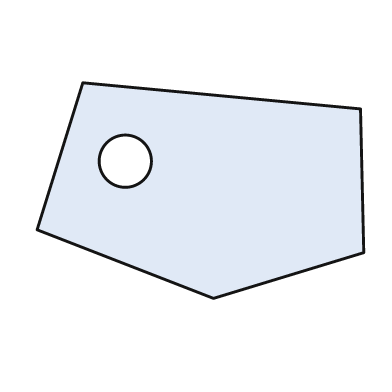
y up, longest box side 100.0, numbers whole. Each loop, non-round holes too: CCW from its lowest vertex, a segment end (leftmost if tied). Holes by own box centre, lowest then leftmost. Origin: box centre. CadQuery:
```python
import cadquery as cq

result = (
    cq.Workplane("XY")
    .moveTo(4.0, -33.0)
    .lineTo(50.0, -19.0)
    .lineTo(49.0, 25.0)
    .lineTo(-36.0, 33.0)
    .lineTo(-50.0, -12.0)
    .close()
    .moveTo(-23.0, 9.0)
    .circle(8.0)
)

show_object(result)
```